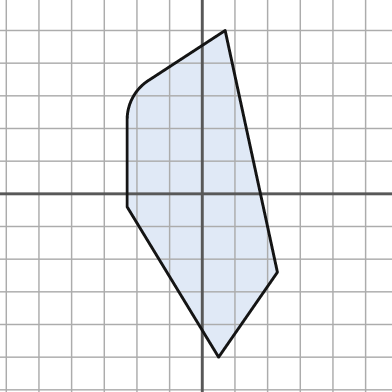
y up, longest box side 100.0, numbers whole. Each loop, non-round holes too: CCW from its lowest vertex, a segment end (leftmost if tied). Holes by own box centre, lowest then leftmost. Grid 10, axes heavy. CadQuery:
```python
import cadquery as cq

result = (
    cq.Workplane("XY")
    .moveTo(5.0, -50.0)
    .lineTo(23.0, -24.0)
    .lineTo(7.0, 50.0)
    .lineTo(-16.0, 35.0)
    .threePointArc((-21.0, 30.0), (-23.0, 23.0))
    .lineTo(-23.0, -4.0)
    .close()
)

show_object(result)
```